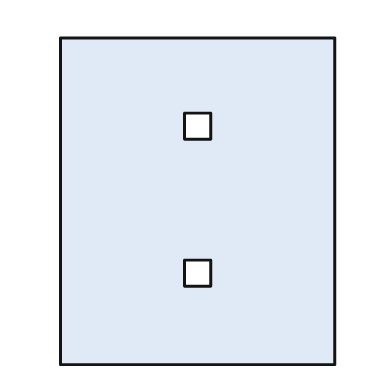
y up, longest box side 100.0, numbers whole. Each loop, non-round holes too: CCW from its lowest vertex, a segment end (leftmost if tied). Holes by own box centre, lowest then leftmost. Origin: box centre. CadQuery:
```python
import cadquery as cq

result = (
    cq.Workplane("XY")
    .moveTo(-42.0, -50.0)
    .lineTo(42.0, -50.0)
    .lineTo(42.0, 50.0)
    .lineTo(-42.0, 50.0)
    .close()
    .moveTo(-4.0, -26.0)
    .lineTo(4.0, -26.0)
    .lineTo(4.0, -18.0)
    .lineTo(-4.0, -18.0)
    .close()
    .moveTo(-4.0, 19.0)
    .lineTo(4.0, 19.0)
    .lineTo(4.0, 27.0)
    .lineTo(-4.0, 27.0)
    .close()
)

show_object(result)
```